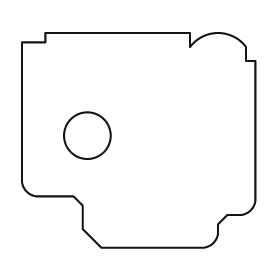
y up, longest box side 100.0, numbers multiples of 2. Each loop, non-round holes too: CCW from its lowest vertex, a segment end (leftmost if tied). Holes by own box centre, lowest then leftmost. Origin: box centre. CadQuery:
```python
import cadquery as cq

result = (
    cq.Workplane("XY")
    .moveTo(-16.0, -46.0)
    .lineTo(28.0, -46.0)
    .threePointArc((32.0, -44.0), (34.0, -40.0))
    .lineTo(34.0, -36.0)
    .lineTo(38.0, -32.0)
    .lineTo(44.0, -32.0)
    .threePointArc((48.0, -30.0), (50.0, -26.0))
    .lineTo(50.0, 34.0)
    .lineTo(46.0, 34.0)
    .lineTo(46.0, 40.0)
    .threePointArc((34.0, 46.0), (22.0, 40.0))
    .lineTo(22.0, 46.0)
    .lineTo(-40.0, 46.0)
    .lineTo(-40.0, 42.0)
    .lineTo(-50.0, 42.0)
    .lineTo(-50.0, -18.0)
    .threePointArc((-48.0, -22.0), (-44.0, -24.0))
    .lineTo(-28.0, -24.0)
    .lineTo(-24.0, -28.0)
    .lineTo(-24.0, -38.0)
    .close()
    .moveTo(-22.0, 2.0)
    .circle(10.0)
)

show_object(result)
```